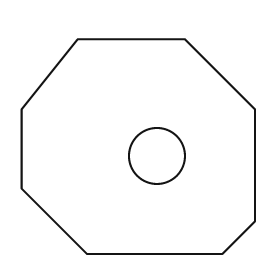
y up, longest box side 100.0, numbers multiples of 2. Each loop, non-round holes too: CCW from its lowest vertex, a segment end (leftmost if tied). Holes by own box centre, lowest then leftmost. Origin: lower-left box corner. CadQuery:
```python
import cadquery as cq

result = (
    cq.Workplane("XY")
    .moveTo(28.0, 0.0)
    .lineTo(86.0, 0.0)
    .lineTo(100.0, 14.0)
    .lineTo(100.0, 62.0)
    .lineTo(70.0, 92.0)
    .lineTo(24.0, 92.0)
    .lineTo(0.0, 62.0)
    .lineTo(0.0, 28.0)
    .close()
    .moveTo(58.0, 42.0)
    .circle(12.0)
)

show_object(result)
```